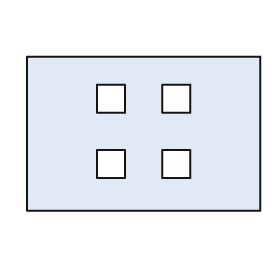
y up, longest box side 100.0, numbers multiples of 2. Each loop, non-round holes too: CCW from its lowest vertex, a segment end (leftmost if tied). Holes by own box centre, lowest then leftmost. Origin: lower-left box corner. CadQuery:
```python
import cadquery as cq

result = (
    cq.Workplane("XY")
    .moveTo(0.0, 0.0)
    .lineTo(100.0, 0.0)
    .lineTo(100.0, 66.0)
    .lineTo(0.0, 66.0)
    .close()
    .moveTo(30.0, 14.0)
    .lineTo(42.0, 14.0)
    .lineTo(42.0, 26.0)
    .lineTo(30.0, 26.0)
    .close()
    .moveTo(58.0, 14.0)
    .lineTo(70.0, 14.0)
    .lineTo(70.0, 26.0)
    .lineTo(58.0, 26.0)
    .close()
    .moveTo(30.0, 42.0)
    .lineTo(42.0, 42.0)
    .lineTo(42.0, 54.0)
    .lineTo(30.0, 54.0)
    .close()
    .moveTo(58.0, 42.0)
    .lineTo(70.0, 42.0)
    .lineTo(70.0, 54.0)
    .lineTo(58.0, 54.0)
    .close()
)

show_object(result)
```